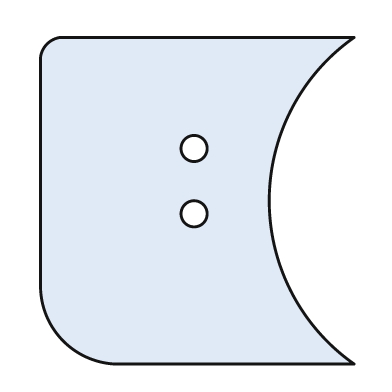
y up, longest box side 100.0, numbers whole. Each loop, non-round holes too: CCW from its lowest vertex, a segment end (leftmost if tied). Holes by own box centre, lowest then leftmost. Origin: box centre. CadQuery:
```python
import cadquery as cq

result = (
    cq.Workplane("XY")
    .moveTo(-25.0, -50.0)
    .lineTo(48.0, -50.0)
    .threePointArc((22.0, 0.0), (48.0, 50.0))
    .lineTo(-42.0, 50.0)
    .threePointArc((-46.0, 48.0), (-48.0, 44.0))
    .lineTo(-48.0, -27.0)
    .threePointArc((-41.0, -43.0), (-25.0, -50.0))
    .close()
    .moveTo(-1.0, -4.0)
    .circle(4.0)
    .moveTo(-1.0, 16.0)
    .circle(4.0)
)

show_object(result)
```